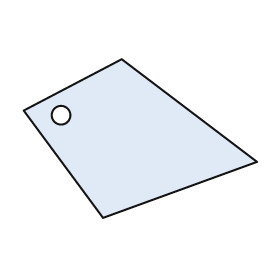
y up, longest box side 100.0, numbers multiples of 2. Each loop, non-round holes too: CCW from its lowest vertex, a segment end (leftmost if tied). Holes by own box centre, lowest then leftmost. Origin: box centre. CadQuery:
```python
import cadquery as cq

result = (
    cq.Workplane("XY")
    .moveTo(-16.0, -34.0)
    .lineTo(50.0, -10.0)
    .lineTo(-8.0, 34.0)
    .lineTo(-50.0, 12.0)
    .close()
    .moveTo(-34.0, 10.0)
    .circle(4.0)
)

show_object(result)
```